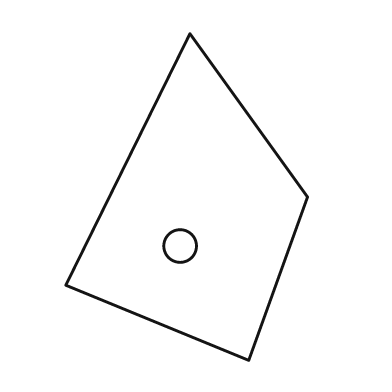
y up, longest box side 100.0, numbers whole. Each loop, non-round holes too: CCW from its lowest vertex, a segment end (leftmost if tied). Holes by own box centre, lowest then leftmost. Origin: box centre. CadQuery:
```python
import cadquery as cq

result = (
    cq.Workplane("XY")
    .moveTo(19.0, -50.0)
    .lineTo(37.0, 0.0)
    .lineTo(1.0, 50.0)
    .lineTo(-37.0, -27.0)
    .close()
    .moveTo(-2.0, -15.0)
    .circle(5.0)
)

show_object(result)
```